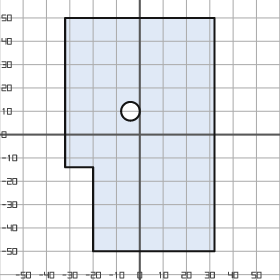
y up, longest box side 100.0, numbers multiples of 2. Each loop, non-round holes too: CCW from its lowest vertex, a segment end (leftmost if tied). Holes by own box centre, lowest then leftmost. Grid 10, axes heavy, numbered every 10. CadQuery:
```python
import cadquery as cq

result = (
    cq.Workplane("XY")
    .moveTo(-20.0, -50.0)
    .lineTo(32.0, -50.0)
    .lineTo(32.0, 50.0)
    .lineTo(-32.0, 50.0)
    .lineTo(-32.0, -14.0)
    .lineTo(-20.0, -14.0)
    .close()
    .moveTo(-4.0, 10.0)
    .circle(4.0)
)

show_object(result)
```